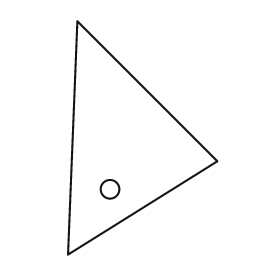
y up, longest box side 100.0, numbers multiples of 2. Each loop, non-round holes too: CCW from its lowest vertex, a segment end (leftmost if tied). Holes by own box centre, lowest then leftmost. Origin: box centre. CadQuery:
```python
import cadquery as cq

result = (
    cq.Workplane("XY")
    .moveTo(-32.0, -50.0)
    .lineTo(32.0, -10.0)
    .lineTo(-28.0, 50.0)
    .close()
    .moveTo(-14.0, -22.0)
    .circle(4.0)
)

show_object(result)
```